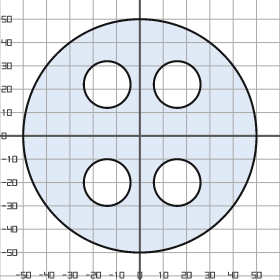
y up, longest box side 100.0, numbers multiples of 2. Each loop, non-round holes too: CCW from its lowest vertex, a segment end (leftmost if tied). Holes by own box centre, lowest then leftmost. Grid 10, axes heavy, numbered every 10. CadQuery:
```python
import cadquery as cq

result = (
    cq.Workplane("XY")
    .moveTo(0.0, 0.0)
    .circle(50.0)
    .moveTo(-14.0, -20.0)
    .circle(10.0)
    .moveTo(16.0, -20.0)
    .circle(10.0)
    .moveTo(-14.0, 22.0)
    .circle(10.0)
    .moveTo(16.0, 22.0)
    .circle(10.0)
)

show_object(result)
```